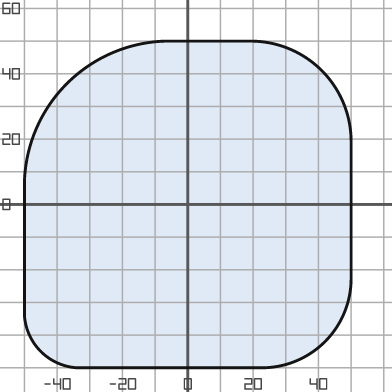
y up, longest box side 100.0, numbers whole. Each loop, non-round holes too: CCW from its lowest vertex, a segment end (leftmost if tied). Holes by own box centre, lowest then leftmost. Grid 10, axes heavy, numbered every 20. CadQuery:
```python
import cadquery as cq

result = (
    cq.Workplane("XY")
    .moveTo(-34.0, -50.0)
    .lineTo(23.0, -50.0)
    .threePointArc((42.0, -42.0), (50.0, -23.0))
    .lineTo(50.0, 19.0)
    .threePointArc((41.0, 41.0), (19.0, 50.0))
    .lineTo(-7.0, 50.0)
    .threePointArc((-37.0, 37.0), (-50.0, 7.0))
    .lineTo(-50.0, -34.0)
    .threePointArc((-45.0, -45.0), (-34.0, -50.0))
    .close()
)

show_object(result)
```